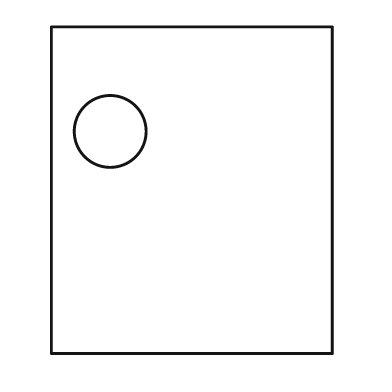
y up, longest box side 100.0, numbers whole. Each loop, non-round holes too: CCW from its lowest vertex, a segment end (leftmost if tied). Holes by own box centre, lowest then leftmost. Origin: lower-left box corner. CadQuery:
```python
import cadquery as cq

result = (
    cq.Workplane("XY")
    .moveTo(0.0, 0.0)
    .lineTo(86.0, 0.0)
    .lineTo(86.0, 100.0)
    .lineTo(0.0, 100.0)
    .close()
    .moveTo(18.0, 68.0)
    .circle(11.0)
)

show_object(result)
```